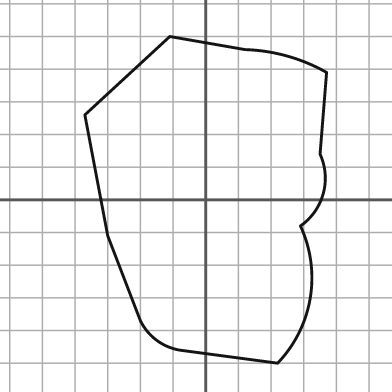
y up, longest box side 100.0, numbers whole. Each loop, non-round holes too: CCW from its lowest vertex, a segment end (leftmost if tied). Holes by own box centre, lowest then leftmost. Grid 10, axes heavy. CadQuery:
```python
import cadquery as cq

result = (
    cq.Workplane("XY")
    .moveTo(22.0, -50.0)
    .threePointArc((32.0, -30.0), (29.0, -8.0))
    .threePointArc((36.0, 2.0), (35.0, 14.0))
    .lineTo(37.0, 39.0)
    .threePointArc((25.0, 44.0), (12.0, 46.0))
    .lineTo(-11.0, 50.0)
    .lineTo(-37.0, 26.0)
    .lineTo(-30.0, -11.0)
    .lineTo(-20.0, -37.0)
    .threePointArc((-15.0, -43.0), (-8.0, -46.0))
    .close()
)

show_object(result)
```